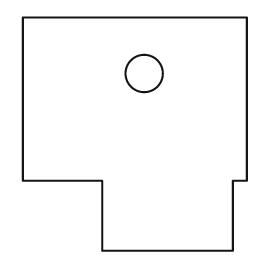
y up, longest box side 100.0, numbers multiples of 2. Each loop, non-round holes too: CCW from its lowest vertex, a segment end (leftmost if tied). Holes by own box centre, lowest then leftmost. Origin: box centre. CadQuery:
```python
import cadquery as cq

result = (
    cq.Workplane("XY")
    .moveTo(-14.0, -50.0)
    .lineTo(42.0, -50.0)
    .lineTo(42.0, -20.0)
    .lineTo(48.0, -20.0)
    .lineTo(48.0, 50.0)
    .lineTo(-48.0, 50.0)
    .lineTo(-48.0, -20.0)
    .lineTo(-14.0, -20.0)
    .close()
    .moveTo(4.0, 26.0)
    .circle(8.0)
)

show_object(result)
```